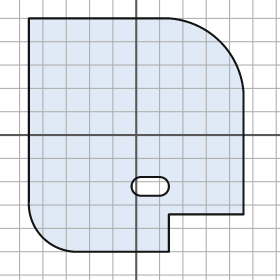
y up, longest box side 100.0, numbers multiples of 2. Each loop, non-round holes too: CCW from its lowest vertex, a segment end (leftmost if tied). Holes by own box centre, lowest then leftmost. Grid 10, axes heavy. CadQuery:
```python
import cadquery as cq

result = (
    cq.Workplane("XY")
    .moveTo(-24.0, -50.0)
    .lineTo(14.0, -50.0)
    .lineTo(14.0, -34.0)
    .lineTo(46.0, -34.0)
    .lineTo(46.0, 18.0)
    .threePointArc((36.0, 40.0), (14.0, 50.0))
    .lineTo(-46.0, 50.0)
    .lineTo(-46.0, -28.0)
    .threePointArc((-40.0, -44.0), (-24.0, -50.0))
    .close()
    .moveTo(2.0, -26.0)
    .lineTo(10.0, -26.0)
    .threePointArc((14.0, -22.0), (10.0, -18.0))
    .lineTo(2.0, -18.0)
    .threePointArc((-2.0, -22.0), (2.0, -26.0))
    .close()
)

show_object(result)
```